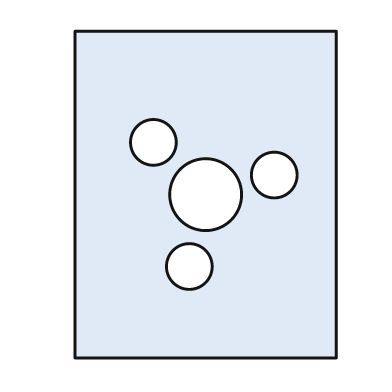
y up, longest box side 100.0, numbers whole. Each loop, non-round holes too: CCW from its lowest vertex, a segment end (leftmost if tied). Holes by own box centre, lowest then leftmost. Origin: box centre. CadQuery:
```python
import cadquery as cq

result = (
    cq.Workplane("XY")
    .moveTo(-40.0, -50.0)
    .lineTo(40.0, -50.0)
    .lineTo(40.0, 50.0)
    .lineTo(-40.0, 50.0)
    .close()
    .moveTo(-5.0, -22.0)
    .circle(7.0)
    .moveTo(0.0, 0.0)
    .circle(11.0)
    .moveTo(21.0, 6.0)
    .circle(7.0)
    .moveTo(-16.0, 16.0)
    .circle(7.0)
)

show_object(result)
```